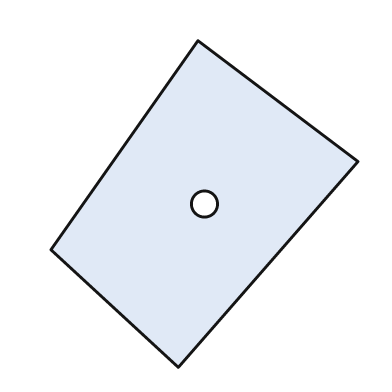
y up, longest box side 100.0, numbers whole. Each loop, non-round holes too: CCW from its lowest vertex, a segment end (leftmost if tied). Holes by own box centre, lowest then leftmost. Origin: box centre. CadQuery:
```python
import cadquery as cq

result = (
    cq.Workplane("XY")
    .moveTo(-8.0, -50.0)
    .lineTo(47.0, 13.0)
    .lineTo(-2.0, 50.0)
    .lineTo(-47.0, -14.0)
    .close()
    .moveTo(0.0, 0.0)
    .circle(4.0)
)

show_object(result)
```